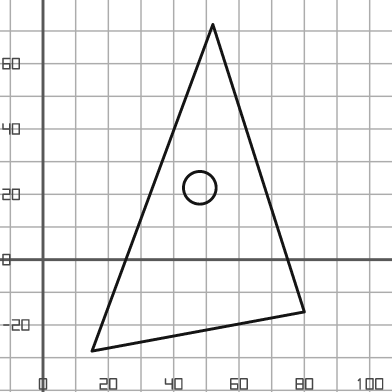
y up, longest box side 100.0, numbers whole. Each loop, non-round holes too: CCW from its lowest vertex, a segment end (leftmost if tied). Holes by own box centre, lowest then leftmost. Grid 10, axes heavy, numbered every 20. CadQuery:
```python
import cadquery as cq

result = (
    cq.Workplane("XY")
    .moveTo(15.0, -28.0)
    .lineTo(80.0, -16.0)
    .lineTo(52.0, 72.0)
    .close()
    .moveTo(48.0, 22.0)
    .circle(5.0)
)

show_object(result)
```